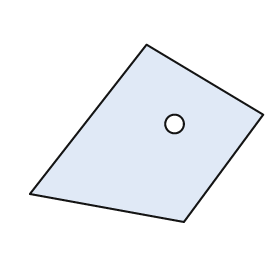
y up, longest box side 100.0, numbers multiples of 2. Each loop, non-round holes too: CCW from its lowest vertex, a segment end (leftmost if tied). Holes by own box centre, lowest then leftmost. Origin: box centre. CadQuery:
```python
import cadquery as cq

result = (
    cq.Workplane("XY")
    .moveTo(16.0, -38.0)
    .lineTo(50.0, 8.0)
    .lineTo(0.0, 38.0)
    .lineTo(-50.0, -26.0)
    .close()
    .moveTo(12.0, 4.0)
    .circle(4.0)
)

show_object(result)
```